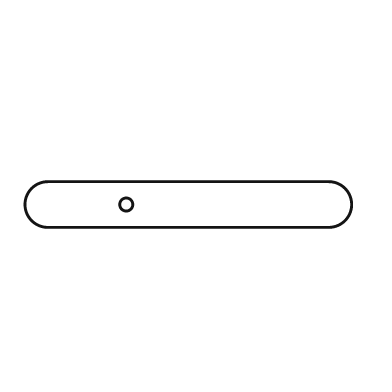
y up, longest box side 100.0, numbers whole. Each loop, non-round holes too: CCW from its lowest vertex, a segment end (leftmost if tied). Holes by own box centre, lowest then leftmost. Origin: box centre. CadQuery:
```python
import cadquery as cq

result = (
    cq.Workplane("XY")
    .moveTo(-43.0, -7.0)
    .lineTo(43.0, -7.0)
    .threePointArc((50.0, 0.0), (43.0, 7.0))
    .lineTo(-43.0, 7.0)
    .threePointArc((-50.0, 0.0), (-43.0, -7.0))
    .close()
    .moveTo(-19.0, 0.0)
    .circle(2.0)
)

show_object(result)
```